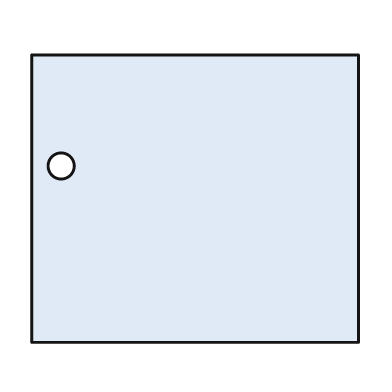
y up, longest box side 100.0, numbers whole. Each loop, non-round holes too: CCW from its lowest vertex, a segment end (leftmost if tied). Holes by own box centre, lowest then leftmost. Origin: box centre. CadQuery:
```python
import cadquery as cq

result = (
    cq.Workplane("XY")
    .moveTo(-50.0, -44.0)
    .lineTo(50.0, -44.0)
    .lineTo(50.0, 44.0)
    .lineTo(-50.0, 44.0)
    .close()
    .moveTo(-41.0, 10.0)
    .circle(4.0)
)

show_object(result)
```